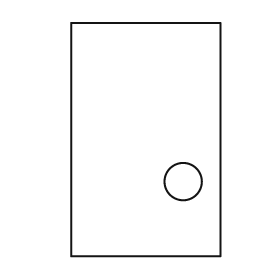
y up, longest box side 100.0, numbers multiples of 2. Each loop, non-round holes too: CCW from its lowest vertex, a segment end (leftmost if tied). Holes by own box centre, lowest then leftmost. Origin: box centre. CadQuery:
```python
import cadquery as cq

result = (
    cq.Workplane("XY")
    .moveTo(-32.0, -50.0)
    .lineTo(32.0, -50.0)
    .lineTo(32.0, 50.0)
    .lineTo(-32.0, 50.0)
    .close()
    .moveTo(16.0, -18.0)
    .circle(8.0)
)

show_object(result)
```